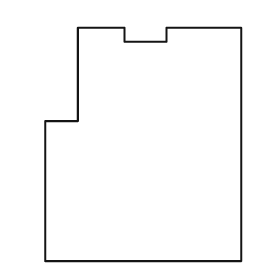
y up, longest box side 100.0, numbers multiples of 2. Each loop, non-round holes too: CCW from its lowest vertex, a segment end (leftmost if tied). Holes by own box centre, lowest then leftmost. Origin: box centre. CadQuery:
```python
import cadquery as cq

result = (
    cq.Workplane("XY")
    .moveTo(-42.0, -50.0)
    .lineTo(42.0, -50.0)
    .lineTo(42.0, 50.0)
    .lineTo(10.0, 50.0)
    .lineTo(10.0, 44.0)
    .lineTo(-8.0, 44.0)
    .lineTo(-8.0, 50.0)
    .lineTo(-28.0, 50.0)
    .lineTo(-28.0, 10.0)
    .lineTo(-42.0, 10.0)
    .close()
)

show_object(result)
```